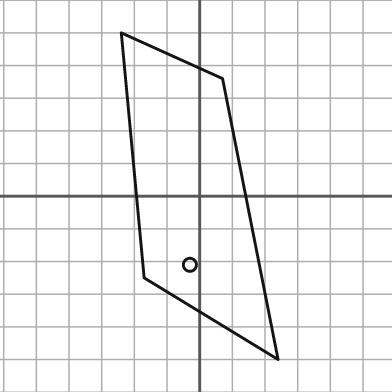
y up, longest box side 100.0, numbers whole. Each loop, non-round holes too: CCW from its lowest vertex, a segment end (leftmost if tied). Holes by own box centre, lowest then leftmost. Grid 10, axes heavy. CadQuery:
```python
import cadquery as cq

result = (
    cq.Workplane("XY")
    .moveTo(24.0, -50.0)
    .lineTo(7.0, 36.0)
    .lineTo(-24.0, 50.0)
    .lineTo(-17.0, -25.0)
    .close()
    .moveTo(-3.0, -21.0)
    .circle(2.0)
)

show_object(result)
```